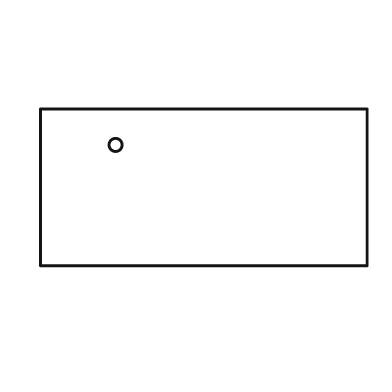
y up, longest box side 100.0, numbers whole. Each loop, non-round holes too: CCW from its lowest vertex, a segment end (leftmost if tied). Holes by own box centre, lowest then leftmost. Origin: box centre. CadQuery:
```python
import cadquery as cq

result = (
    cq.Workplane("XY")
    .moveTo(-50.0, -24.0)
    .lineTo(50.0, -24.0)
    .lineTo(50.0, 24.0)
    .lineTo(-50.0, 24.0)
    .close()
    .moveTo(-27.0, 13.0)
    .circle(2.0)
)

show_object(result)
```